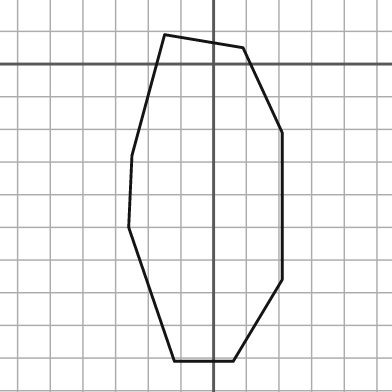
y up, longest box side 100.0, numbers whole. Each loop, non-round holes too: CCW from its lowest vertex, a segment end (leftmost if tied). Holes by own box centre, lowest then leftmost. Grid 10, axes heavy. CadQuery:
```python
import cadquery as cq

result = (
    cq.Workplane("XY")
    .moveTo(-12.0, -91.0)
    .lineTo(6.0, -91.0)
    .lineTo(21.0, -66.0)
    .lineTo(21.0, -21.0)
    .lineTo(9.0, 5.0)
    .lineTo(-15.0, 9.0)
    .lineTo(-25.0, -28.0)
    .lineTo(-26.0, -50.0)
    .close()
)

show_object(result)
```